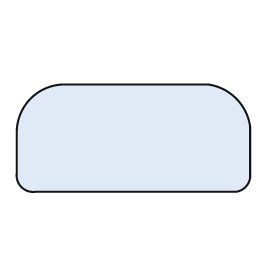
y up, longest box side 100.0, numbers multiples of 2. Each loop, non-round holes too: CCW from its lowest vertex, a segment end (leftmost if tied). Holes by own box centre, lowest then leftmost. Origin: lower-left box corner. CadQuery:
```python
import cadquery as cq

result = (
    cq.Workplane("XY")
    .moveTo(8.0, 0.0)
    .lineTo(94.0, 0.0)
    .threePointArc((98.0, 2.0), (100.0, 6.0))
    .lineTo(100.0, 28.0)
    .threePointArc((94.0, 40.0), (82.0, 46.0))
    .lineTo(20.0, 46.0)
    .threePointArc((6.0, 40.0), (0.0, 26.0))
    .lineTo(0.0, 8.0)
    .threePointArc((2.0, 2.0), (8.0, 0.0))
    .close()
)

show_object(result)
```